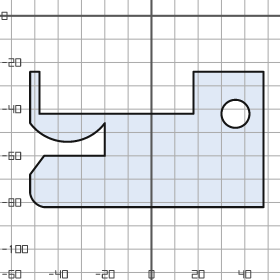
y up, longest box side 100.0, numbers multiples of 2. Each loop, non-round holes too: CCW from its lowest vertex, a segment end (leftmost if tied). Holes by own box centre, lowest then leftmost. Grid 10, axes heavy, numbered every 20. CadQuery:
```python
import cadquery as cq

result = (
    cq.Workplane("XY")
    .moveTo(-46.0, -82.0)
    .lineTo(48.0, -82.0)
    .lineTo(48.0, -24.0)
    .lineTo(18.0, -24.0)
    .lineTo(18.0, -42.0)
    .lineTo(-48.0, -42.0)
    .lineTo(-48.0, -24.0)
    .lineTo(-52.0, -24.0)
    .lineTo(-52.0, -46.0)
    .threePointArc((-36.0, -54.0), (-20.0, -46.0))
    .lineTo(-20.0, -60.0)
    .lineTo(-46.0, -60.0)
    .lineTo(-52.0, -68.0)
    .lineTo(-52.0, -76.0)
    .threePointArc((-50.0, -80.0), (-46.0, -82.0))
    .close()
    .moveTo(36.0, -42.0)
    .circle(6.0)
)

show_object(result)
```